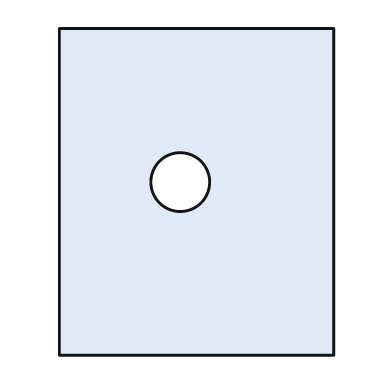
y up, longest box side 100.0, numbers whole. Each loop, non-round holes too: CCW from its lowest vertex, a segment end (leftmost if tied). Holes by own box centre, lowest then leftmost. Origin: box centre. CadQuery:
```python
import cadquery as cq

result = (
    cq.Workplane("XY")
    .moveTo(-42.0, -50.0)
    .lineTo(42.0, -50.0)
    .lineTo(42.0, 50.0)
    .lineTo(-42.0, 50.0)
    .close()
    .moveTo(-5.0, 3.0)
    .circle(9.0)
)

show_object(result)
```